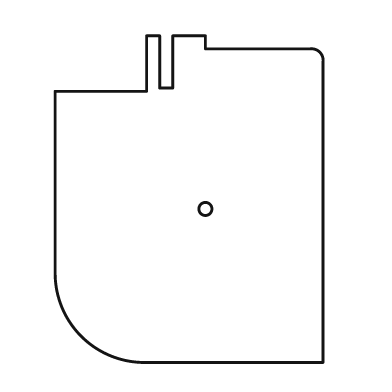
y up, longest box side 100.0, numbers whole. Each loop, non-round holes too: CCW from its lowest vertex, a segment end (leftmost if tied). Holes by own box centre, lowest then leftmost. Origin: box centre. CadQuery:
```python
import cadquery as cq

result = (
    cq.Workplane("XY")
    .moveTo(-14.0, -50.0)
    .lineTo(41.0, -50.0)
    .lineTo(41.0, 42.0)
    .threePointArc((40.0, 45.0), (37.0, 46.0))
    .lineTo(5.0, 46.0)
    .lineTo(5.0, 50.0)
    .lineTo(-5.0, 50.0)
    .lineTo(-5.0, 34.0)
    .lineTo(-9.0, 34.0)
    .lineTo(-9.0, 50.0)
    .lineTo(-13.0, 50.0)
    .lineTo(-13.0, 33.0)
    .lineTo(-41.0, 33.0)
    .lineTo(-41.0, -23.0)
    .threePointArc((-33.0, -42.0), (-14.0, -50.0))
    .close()
    .moveTo(5.0, -3.0)
    .circle(2.0)
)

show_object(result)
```